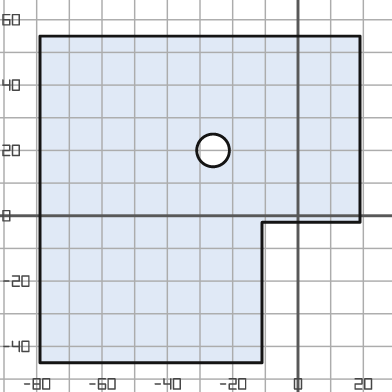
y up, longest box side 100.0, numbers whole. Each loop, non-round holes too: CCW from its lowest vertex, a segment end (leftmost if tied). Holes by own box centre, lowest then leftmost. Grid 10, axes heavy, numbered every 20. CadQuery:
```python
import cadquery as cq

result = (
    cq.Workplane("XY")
    .moveTo(-79.0, -45.0)
    .lineTo(-11.0, -45.0)
    .lineTo(-11.0, -2.0)
    .lineTo(19.0, -2.0)
    .lineTo(19.0, 55.0)
    .lineTo(-79.0, 55.0)
    .close()
    .moveTo(-26.0, 20.0)
    .circle(5.0)
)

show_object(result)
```